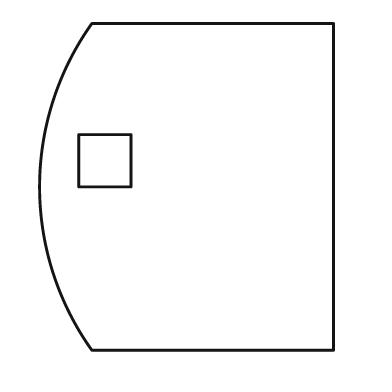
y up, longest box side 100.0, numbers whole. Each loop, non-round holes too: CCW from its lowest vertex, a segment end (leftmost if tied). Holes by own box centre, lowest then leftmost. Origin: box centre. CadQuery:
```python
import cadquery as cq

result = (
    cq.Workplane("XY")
    .moveTo(-29.0, -50.0)
    .lineTo(45.0, -50.0)
    .lineTo(45.0, 50.0)
    .lineTo(-29.0, 50.0)
    .threePointArc((-45.0, 0.0), (-29.0, -50.0))
    .close()
    .moveTo(-33.0, 0.0)
    .lineTo(-17.0, 0.0)
    .lineTo(-17.0, 16.0)
    .lineTo(-33.0, 16.0)
    .close()
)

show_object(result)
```